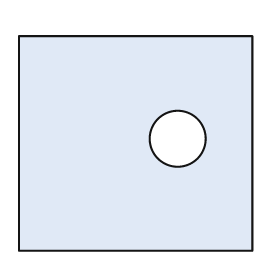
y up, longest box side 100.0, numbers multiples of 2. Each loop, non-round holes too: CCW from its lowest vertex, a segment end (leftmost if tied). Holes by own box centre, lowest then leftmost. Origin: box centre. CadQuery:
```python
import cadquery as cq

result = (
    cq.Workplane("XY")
    .moveTo(-50.0, -46.0)
    .lineTo(50.0, -46.0)
    .lineTo(50.0, 46.0)
    .lineTo(-50.0, 46.0)
    .close()
    .moveTo(18.0, 2.0)
    .circle(12.0)
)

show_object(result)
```